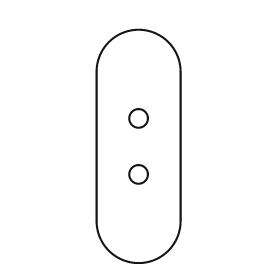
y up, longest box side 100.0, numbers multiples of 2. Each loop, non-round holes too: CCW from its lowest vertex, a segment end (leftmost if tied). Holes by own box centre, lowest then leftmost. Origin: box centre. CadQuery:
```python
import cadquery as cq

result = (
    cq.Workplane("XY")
    .moveTo(-18.0, -32.0)
    .threePointArc((0.0, -50.0), (18.0, -32.0))
    .lineTo(18.0, 32.0)
    .threePointArc((0.0, 50.0), (-18.0, 32.0))
    .close()
    .moveTo(0.0, -12.0)
    .circle(4.0)
    .moveTo(0.0, 12.0)
    .circle(4.0)
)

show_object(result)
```